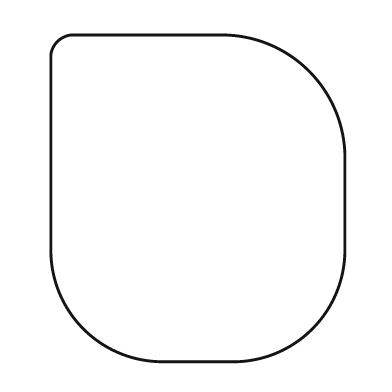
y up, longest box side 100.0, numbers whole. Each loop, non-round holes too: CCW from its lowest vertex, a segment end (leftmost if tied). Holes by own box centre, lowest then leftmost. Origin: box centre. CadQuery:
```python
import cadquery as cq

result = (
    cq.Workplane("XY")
    .moveTo(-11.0, -50.0)
    .lineTo(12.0, -50.0)
    .threePointArc((35.0, -40.0), (45.0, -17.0))
    .lineTo(45.0, 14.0)
    .threePointArc((34.0, 39.0), (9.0, 50.0))
    .lineTo(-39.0, 50.0)
    .threePointArc((-43.0, 48.0), (-45.0, 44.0))
    .lineTo(-45.0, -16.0)
    .threePointArc((-35.0, -40.0), (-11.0, -50.0))
    .close()
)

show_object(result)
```